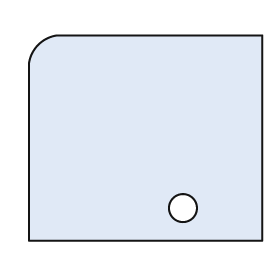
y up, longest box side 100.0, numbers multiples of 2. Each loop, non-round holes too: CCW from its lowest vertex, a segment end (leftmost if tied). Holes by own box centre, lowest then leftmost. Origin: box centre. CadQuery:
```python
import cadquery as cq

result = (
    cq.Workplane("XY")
    .moveTo(-50.0, -44.0)
    .lineTo(50.0, -44.0)
    .lineTo(50.0, 44.0)
    .lineTo(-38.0, 44.0)
    .threePointArc((-46.0, 40.0), (-50.0, 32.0))
    .close()
    .moveTo(16.0, -30.0)
    .circle(6.0)
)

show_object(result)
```